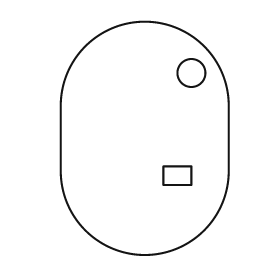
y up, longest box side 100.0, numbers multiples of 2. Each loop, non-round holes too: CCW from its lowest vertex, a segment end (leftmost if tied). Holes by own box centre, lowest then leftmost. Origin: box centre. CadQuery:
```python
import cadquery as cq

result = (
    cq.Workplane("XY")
    .moveTo(-36.0, -14.0)
    .threePointArc((0.0, -50.0), (36.0, -14.0))
    .lineTo(36.0, 14.0)
    .threePointArc((0.0, 50.0), (-36.0, 14.0))
    .close()
    .moveTo(8.0, -20.0)
    .lineTo(20.0, -20.0)
    .lineTo(20.0, -12.0)
    .lineTo(8.0, -12.0)
    .close()
    .moveTo(20.0, 28.0)
    .circle(6.0)
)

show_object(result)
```